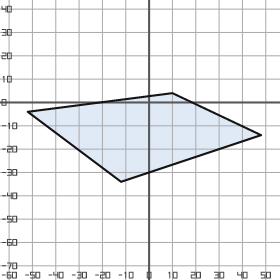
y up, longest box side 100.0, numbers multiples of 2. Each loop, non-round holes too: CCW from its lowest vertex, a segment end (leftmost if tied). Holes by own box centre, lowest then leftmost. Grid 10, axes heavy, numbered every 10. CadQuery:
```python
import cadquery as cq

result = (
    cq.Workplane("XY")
    .moveTo(-12.0, -34.0)
    .lineTo(48.0, -14.0)
    .lineTo(10.0, 4.0)
    .lineTo(-52.0, -4.0)
    .close()
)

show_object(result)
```